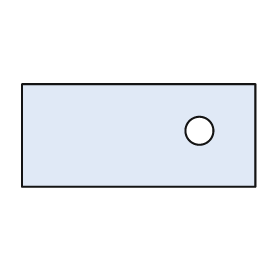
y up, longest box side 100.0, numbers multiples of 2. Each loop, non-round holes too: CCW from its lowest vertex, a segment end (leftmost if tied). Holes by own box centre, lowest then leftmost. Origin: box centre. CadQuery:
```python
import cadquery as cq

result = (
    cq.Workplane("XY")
    .moveTo(-50.0, -22.0)
    .lineTo(50.0, -22.0)
    .lineTo(50.0, 22.0)
    .lineTo(-50.0, 22.0)
    .close()
    .moveTo(26.0, 2.0)
    .circle(6.0)
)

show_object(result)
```